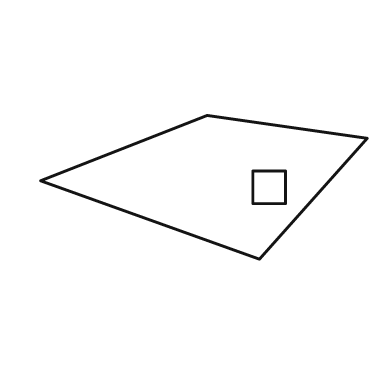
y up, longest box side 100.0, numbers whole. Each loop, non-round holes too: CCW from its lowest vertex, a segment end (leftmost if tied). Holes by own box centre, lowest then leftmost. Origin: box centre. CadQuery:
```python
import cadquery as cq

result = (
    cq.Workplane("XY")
    .moveTo(17.0, -22.0)
    .lineTo(50.0, 15.0)
    .lineTo(1.0, 22.0)
    .lineTo(-50.0, 2.0)
    .close()
    .moveTo(15.0, -5.0)
    .lineTo(25.0, -5.0)
    .lineTo(25.0, 5.0)
    .lineTo(15.0, 5.0)
    .close()
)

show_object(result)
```